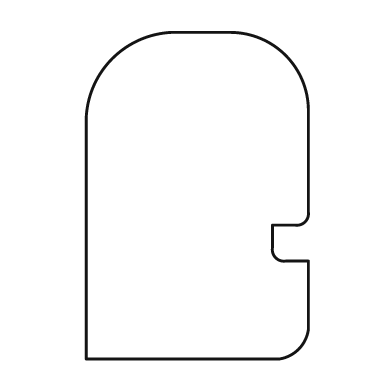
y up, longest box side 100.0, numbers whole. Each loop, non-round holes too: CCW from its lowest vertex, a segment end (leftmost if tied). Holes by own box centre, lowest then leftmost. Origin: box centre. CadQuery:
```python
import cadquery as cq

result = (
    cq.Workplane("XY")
    .moveTo(-34.0, -50.0)
    .lineTo(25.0, -50.0)
    .threePointArc((31.0, -47.0), (34.0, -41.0))
    .lineTo(34.0, -20.0)
    .lineTo(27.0, -20.0)
    .threePointArc((24.0, -19.0), (23.0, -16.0))
    .lineTo(23.0, -9.0)
    .lineTo(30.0, -9.0)
    .threePointArc((33.0, -8.0), (34.0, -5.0))
    .lineTo(34.0, 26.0)
    .threePointArc((27.0, 43.0), (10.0, 50.0))
    .lineTo(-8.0, 50.0)
    .threePointArc((-26.0, 42.0), (-34.0, 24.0))
    .close()
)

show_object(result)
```